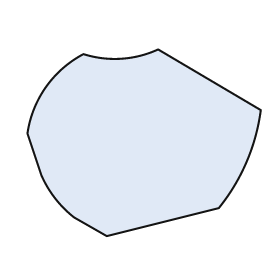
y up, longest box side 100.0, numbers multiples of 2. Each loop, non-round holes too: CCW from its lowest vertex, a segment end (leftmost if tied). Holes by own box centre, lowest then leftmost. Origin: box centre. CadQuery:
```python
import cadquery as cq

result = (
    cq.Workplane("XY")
    .moveTo(-16.0, -40.0)
    .lineTo(32.0, -28.0)
    .threePointArc((44.0, -8.0), (50.0, 14.0))
    .lineTo(6.0, 40.0)
    .threePointArc((-10.0, 36.0), (-26.0, 38.0))
    .threePointArc((-42.0, 24.0), (-50.0, 4.0))
    .lineTo(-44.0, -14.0)
    .threePointArc((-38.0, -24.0), (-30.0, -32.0))
    .close()
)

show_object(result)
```